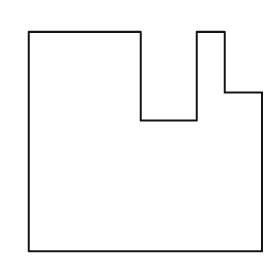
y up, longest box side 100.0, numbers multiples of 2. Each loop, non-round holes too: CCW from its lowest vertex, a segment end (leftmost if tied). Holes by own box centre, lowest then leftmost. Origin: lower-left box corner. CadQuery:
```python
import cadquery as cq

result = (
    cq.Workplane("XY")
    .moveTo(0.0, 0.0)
    .lineTo(100.0, 0.0)
    .lineTo(100.0, 68.0)
    .lineTo(84.0, 68.0)
    .lineTo(84.0, 94.0)
    .lineTo(72.0, 94.0)
    .lineTo(72.0, 56.0)
    .lineTo(48.0, 56.0)
    .lineTo(48.0, 94.0)
    .lineTo(0.0, 94.0)
    .close()
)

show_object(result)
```